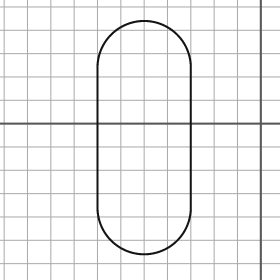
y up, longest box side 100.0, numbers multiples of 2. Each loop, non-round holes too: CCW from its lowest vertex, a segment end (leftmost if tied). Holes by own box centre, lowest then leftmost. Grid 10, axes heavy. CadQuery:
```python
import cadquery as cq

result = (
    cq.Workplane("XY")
    .moveTo(-70.0, -36.0)
    .threePointArc((-50.0, -56.0), (-30.0, -36.0))
    .lineTo(-30.0, 24.0)
    .threePointArc((-50.0, 44.0), (-70.0, 24.0))
    .close()
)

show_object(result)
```